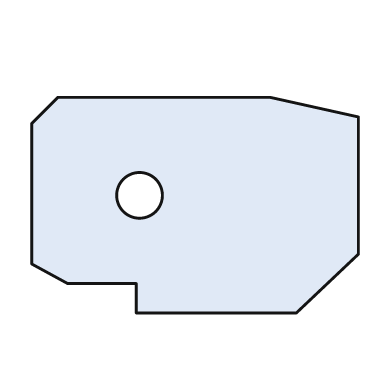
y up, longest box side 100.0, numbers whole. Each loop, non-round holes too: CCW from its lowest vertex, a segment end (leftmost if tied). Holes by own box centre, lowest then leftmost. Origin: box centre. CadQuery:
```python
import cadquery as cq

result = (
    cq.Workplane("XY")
    .moveTo(-18.0, -33.0)
    .lineTo(31.0, -33.0)
    .lineTo(50.0, -15.0)
    .lineTo(50.0, 27.0)
    .lineTo(23.0, 33.0)
    .lineTo(-42.0, 33.0)
    .lineTo(-50.0, 25.0)
    .lineTo(-50.0, -18.0)
    .lineTo(-39.0, -24.0)
    .lineTo(-18.0, -24.0)
    .close()
    .moveTo(-17.0, 3.0)
    .circle(7.0)
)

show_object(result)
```